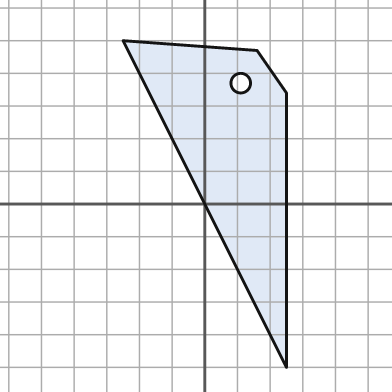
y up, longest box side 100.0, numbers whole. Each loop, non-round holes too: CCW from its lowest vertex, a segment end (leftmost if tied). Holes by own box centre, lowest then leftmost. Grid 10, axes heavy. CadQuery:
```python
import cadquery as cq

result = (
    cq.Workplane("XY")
    .moveTo(25.0, -50.0)
    .lineTo(25.0, 34.0)
    .lineTo(16.0, 47.0)
    .lineTo(-25.0, 50.0)
    .close()
    .moveTo(11.0, 37.0)
    .circle(3.0)
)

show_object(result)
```